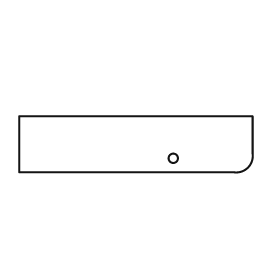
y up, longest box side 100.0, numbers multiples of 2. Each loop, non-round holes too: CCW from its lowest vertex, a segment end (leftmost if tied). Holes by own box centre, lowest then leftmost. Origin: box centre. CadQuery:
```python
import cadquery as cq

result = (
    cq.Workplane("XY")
    .moveTo(-50.0, -12.0)
    .lineTo(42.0, -12.0)
    .threePointArc((48.0, -10.0), (50.0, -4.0))
    .lineTo(50.0, 12.0)
    .lineTo(-50.0, 12.0)
    .close()
    .moveTo(16.0, -6.0)
    .circle(2.0)
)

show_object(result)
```